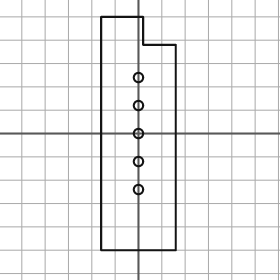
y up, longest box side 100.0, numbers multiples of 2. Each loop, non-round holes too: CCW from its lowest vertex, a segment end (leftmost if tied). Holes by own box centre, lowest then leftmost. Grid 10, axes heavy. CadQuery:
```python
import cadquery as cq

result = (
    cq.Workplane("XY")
    .moveTo(-16.0, -50.0)
    .lineTo(16.0, -50.0)
    .lineTo(16.0, 38.0)
    .lineTo(2.0, 38.0)
    .lineTo(2.0, 50.0)
    .lineTo(-16.0, 50.0)
    .close()
    .moveTo(0.0, -24.0)
    .circle(2.0)
    .moveTo(0.0, -12.0)
    .circle(2.0)
    .moveTo(0.0, 0.0)
    .circle(2.0)
    .moveTo(0.0, 12.0)
    .circle(2.0)
    .moveTo(0.0, 24.0)
    .circle(2.0)
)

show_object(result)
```